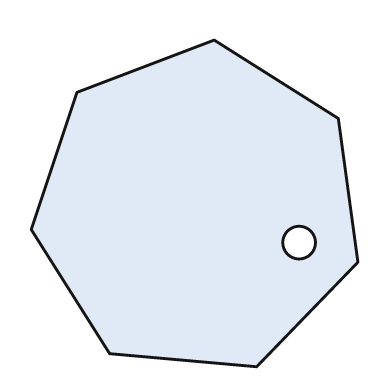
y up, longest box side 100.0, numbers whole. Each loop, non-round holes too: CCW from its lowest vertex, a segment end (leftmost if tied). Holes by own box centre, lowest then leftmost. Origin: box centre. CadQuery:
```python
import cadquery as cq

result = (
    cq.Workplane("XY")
    .moveTo(19.0, -50.0)
    .lineTo(50.0, -18.0)
    .lineTo(44.0, 26.0)
    .lineTo(6.0, 50.0)
    .lineTo(-36.0, 34.0)
    .lineTo(-50.0, -8.0)
    .lineTo(-26.0, -46.0)
    .close()
    .moveTo(32.0, -12.0)
    .circle(5.0)
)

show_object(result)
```